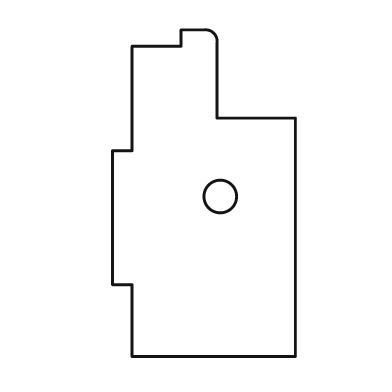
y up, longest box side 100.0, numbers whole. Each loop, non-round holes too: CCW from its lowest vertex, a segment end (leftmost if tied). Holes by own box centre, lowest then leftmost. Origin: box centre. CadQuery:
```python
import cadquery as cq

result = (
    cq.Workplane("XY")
    .moveTo(-22.0, -50.0)
    .lineTo(28.0, -50.0)
    .lineTo(28.0, 23.0)
    .lineTo(4.0, 23.0)
    .lineTo(4.0, 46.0)
    .threePointArc((3.0, 49.0), (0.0, 50.0))
    .lineTo(-7.0, 50.0)
    .lineTo(-7.0, 45.0)
    .lineTo(-22.0, 45.0)
    .lineTo(-22.0, 13.0)
    .lineTo(-28.0, 13.0)
    .lineTo(-28.0, -28.0)
    .lineTo(-22.0, -28.0)
    .close()
    .moveTo(5.0, -1.0)
    .circle(5.0)
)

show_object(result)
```